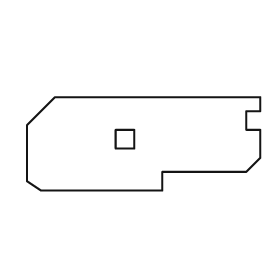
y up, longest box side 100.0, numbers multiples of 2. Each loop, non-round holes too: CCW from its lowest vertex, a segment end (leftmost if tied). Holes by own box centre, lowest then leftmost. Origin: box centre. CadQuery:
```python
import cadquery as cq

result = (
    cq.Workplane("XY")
    .moveTo(-44.0, -20.0)
    .lineTo(8.0, -20.0)
    .lineTo(8.0, -12.0)
    .lineTo(44.0, -12.0)
    .lineTo(50.0, -6.0)
    .lineTo(50.0, 6.0)
    .lineTo(44.0, 6.0)
    .lineTo(44.0, 14.0)
    .lineTo(50.0, 14.0)
    .lineTo(50.0, 20.0)
    .lineTo(-38.0, 20.0)
    .lineTo(-50.0, 8.0)
    .lineTo(-50.0, -16.0)
    .close()
    .moveTo(-12.0, -2.0)
    .lineTo(-4.0, -2.0)
    .lineTo(-4.0, 6.0)
    .lineTo(-12.0, 6.0)
    .close()
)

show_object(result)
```